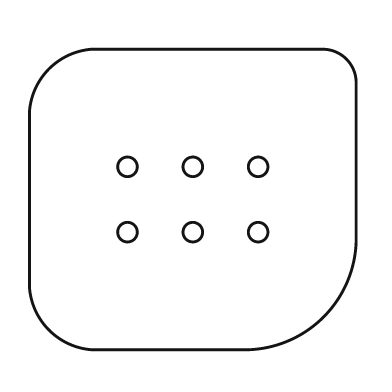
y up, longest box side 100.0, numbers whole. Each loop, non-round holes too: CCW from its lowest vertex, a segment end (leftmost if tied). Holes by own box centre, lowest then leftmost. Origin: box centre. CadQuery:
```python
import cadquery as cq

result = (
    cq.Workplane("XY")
    .moveTo(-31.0, -46.0)
    .lineTo(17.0, -46.0)
    .threePointArc((40.0, -36.0), (50.0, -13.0))
    .lineTo(50.0, 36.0)
    .threePointArc((47.0, 43.0), (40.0, 46.0))
    .lineTo(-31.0, 46.0)
    .threePointArc((-44.0, 40.0), (-50.0, 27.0))
    .lineTo(-50.0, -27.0)
    .threePointArc((-44.0, -40.0), (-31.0, -46.0))
    .close()
    .moveTo(-20.0, -10.0)
    .circle(3.0)
    .moveTo(0.0, -10.0)
    .circle(3.0)
    .moveTo(20.0, -10.0)
    .circle(3.0)
    .moveTo(-20.0, 10.0)
    .circle(3.0)
    .moveTo(0.0, 10.0)
    .circle(3.0)
    .moveTo(20.0, 10.0)
    .circle(3.0)
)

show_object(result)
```